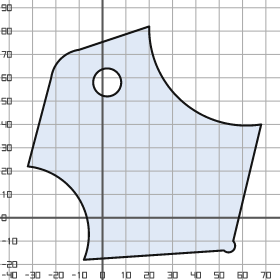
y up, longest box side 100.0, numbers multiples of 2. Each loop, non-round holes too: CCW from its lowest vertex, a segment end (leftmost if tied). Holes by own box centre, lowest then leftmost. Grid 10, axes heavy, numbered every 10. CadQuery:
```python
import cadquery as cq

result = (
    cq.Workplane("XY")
    .moveTo(-8.0, -18.0)
    .lineTo(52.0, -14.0)
    .threePointArc((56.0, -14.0), (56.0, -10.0))
    .lineTo(68.0, 40.0)
    .threePointArc((34.0, 50.0), (20.0, 82.0))
    .lineTo(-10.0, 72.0)
    .threePointArc((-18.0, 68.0), (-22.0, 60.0))
    .lineTo(-32.0, 22.0)
    .threePointArc((-10.0, 8.0), (-8.0, -18.0))
    .close()
    .moveTo(2.0, 58.0)
    .circle(6.0)
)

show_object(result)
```